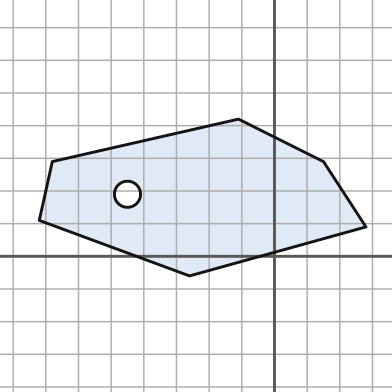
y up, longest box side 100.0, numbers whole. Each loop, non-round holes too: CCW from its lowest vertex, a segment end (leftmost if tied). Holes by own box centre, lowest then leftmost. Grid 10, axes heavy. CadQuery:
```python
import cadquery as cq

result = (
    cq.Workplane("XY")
    .moveTo(-26.0, -6.0)
    .lineTo(28.0, 9.0)
    .lineTo(15.0, 29.0)
    .lineTo(-11.0, 42.0)
    .lineTo(-68.0, 29.0)
    .lineTo(-72.0, 11.0)
    .close()
    .moveTo(-45.0, 19.0)
    .circle(4.0)
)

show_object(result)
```